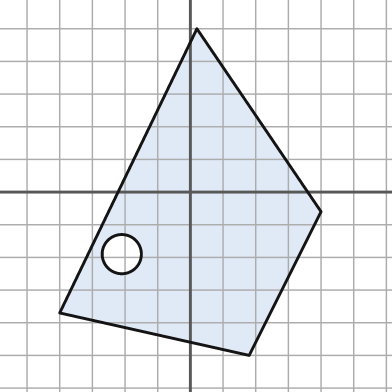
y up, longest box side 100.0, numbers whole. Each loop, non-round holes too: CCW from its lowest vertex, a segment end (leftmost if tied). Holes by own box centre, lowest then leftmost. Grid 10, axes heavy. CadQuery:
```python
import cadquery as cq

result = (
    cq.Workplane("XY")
    .moveTo(18.0, -50.0)
    .lineTo(40.0, -6.0)
    .lineTo(2.0, 50.0)
    .lineTo(-40.0, -37.0)
    .close()
    .moveTo(-21.0, -19.0)
    .circle(6.0)
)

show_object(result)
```